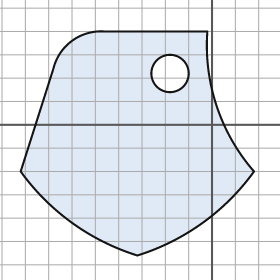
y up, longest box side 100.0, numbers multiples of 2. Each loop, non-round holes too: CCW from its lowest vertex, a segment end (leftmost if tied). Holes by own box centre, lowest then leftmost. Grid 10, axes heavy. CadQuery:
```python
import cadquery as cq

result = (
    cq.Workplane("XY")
    .moveTo(-32.0, -56.0)
    .threePointArc((-4.0, -42.0), (18.0, -20.0))
    .threePointArc((2.0, 8.0), (-2.0, 40.0))
    .lineTo(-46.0, 40.0)
    .threePointArc((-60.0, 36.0), (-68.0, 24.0))
    .lineTo(-82.0, -20.0)
    .threePointArc((-60.0, -42.0), (-32.0, -56.0))
    .close()
    .moveTo(-18.0, 22.0)
    .circle(8.0)
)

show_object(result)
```